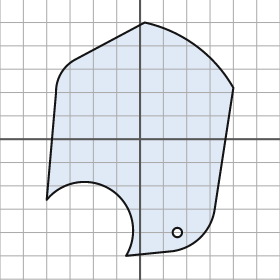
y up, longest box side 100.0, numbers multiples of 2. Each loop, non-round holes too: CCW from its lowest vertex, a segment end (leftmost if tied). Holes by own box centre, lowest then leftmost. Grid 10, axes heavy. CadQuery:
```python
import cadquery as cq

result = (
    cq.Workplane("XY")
    .moveTo(-6.0, -50.0)
    .lineTo(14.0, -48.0)
    .threePointArc((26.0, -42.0), (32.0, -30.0))
    .lineTo(40.0, 22.0)
    .threePointArc((24.0, 40.0), (2.0, 50.0))
    .lineTo(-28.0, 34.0)
    .threePointArc((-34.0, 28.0), (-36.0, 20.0))
    .lineTo(-40.0, -26.0)
    .threePointArc((-12.0, -22.0), (-6.0, -50.0))
    .close()
    .moveTo(16.0, -40.0)
    .circle(2.0)
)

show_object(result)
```